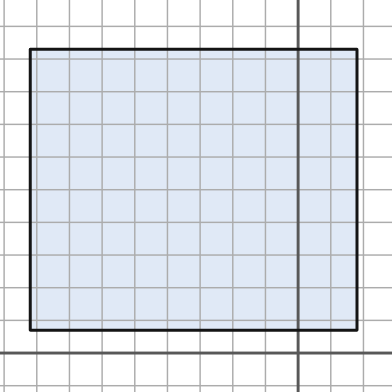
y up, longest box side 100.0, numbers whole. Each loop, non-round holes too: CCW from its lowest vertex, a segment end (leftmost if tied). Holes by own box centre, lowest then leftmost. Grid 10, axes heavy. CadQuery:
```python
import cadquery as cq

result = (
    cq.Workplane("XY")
    .moveTo(-82.0, 7.0)
    .lineTo(18.0, 7.0)
    .lineTo(18.0, 93.0)
    .lineTo(-82.0, 93.0)
    .close()
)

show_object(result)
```